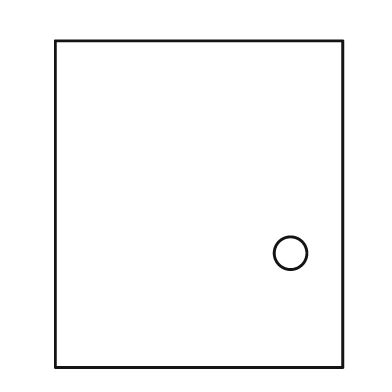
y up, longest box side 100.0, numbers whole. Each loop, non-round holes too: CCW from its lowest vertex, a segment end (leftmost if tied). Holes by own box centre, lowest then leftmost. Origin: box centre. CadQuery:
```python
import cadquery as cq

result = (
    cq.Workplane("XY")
    .moveTo(-44.0, -50.0)
    .lineTo(44.0, -50.0)
    .lineTo(44.0, 50.0)
    .lineTo(-44.0, 50.0)
    .close()
    .moveTo(28.0, -15.0)
    .circle(5.0)
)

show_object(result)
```